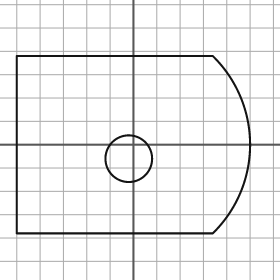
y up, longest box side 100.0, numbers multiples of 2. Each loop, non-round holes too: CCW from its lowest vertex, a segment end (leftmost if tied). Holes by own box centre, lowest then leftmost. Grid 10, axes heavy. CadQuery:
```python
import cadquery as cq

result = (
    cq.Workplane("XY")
    .moveTo(-50.0, -38.0)
    .lineTo(34.0, -38.0)
    .threePointArc((50.0, 0.0), (34.0, 38.0))
    .lineTo(-50.0, 38.0)
    .close()
    .moveTo(-2.0, -6.0)
    .circle(10.0)
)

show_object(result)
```